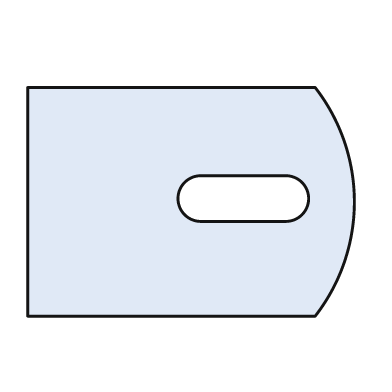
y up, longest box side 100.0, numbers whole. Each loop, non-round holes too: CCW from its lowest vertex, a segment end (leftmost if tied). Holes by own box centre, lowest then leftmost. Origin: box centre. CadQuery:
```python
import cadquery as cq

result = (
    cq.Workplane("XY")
    .moveTo(-50.0, -35.0)
    .lineTo(38.0, -35.0)
    .threePointArc((50.0, 0.0), (38.0, 35.0))
    .lineTo(-50.0, 35.0)
    .close()
    .moveTo(3.0, -6.0)
    .lineTo(29.0, -6.0)
    .threePointArc((36.0, 1.0), (29.0, 8.0))
    .lineTo(3.0, 8.0)
    .threePointArc((-4.0, 1.0), (3.0, -6.0))
    .close()
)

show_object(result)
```